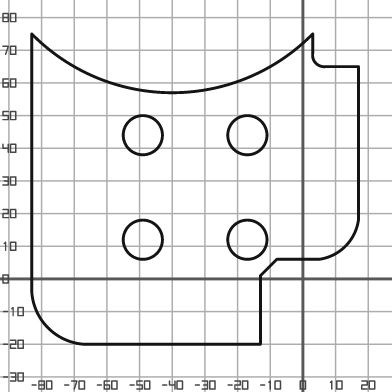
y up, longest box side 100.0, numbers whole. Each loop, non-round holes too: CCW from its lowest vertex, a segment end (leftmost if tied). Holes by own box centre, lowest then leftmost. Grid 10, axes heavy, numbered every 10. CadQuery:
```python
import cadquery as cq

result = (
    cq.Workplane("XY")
    .moveTo(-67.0, -20.0)
    .lineTo(-13.0, -20.0)
    .lineTo(-13.0, 1.0)
    .lineTo(-8.0, 6.0)
    .lineTo(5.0, 6.0)
    .threePointArc((13.0, 10.0), (17.0, 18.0))
    .lineTo(17.0, 65.0)
    .lineTo(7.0, 65.0)
    .threePointArc((4.0, 66.0), (3.0, 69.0))
    .lineTo(3.0, 75.0)
    .threePointArc((-40.0, 57.0), (-83.0, 75.0))
    .lineTo(-83.0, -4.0)
    .threePointArc((-78.0, -15.0), (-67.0, -20.0))
    .close()
    .moveTo(-49.0, 12.0)
    .circle(6.0)
    .moveTo(-17.0, 12.0)
    .circle(6.0)
    .moveTo(-49.0, 44.0)
    .circle(6.0)
    .moveTo(-17.0, 44.0)
    .circle(6.0)
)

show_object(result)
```